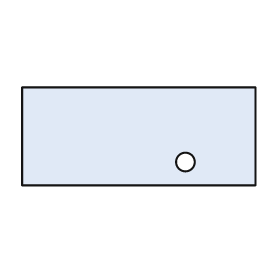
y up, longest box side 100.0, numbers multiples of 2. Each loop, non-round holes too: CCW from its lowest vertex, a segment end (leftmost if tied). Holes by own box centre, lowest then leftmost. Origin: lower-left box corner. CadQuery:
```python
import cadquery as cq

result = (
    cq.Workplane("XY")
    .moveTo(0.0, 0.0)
    .lineTo(100.0, 0.0)
    .lineTo(100.0, 42.0)
    .lineTo(0.0, 42.0)
    .close()
    .moveTo(70.0, 10.0)
    .circle(4.0)
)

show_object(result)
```